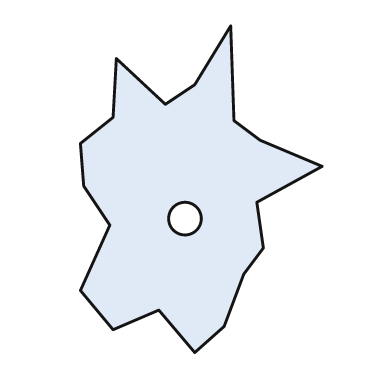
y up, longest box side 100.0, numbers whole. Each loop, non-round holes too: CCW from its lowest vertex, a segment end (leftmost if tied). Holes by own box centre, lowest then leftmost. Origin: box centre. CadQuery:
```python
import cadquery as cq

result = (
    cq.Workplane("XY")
    .moveTo(-2.0, -50.0)
    .lineTo(7.0, -42.0)
    .lineTo(13.0, -26.0)
    .lineTo(19.0, -18.0)
    .lineTo(17.0, -4.0)
    .lineTo(37.0, 7.0)
    .lineTo(18.0, 15.0)
    .lineTo(10.0, 21.0)
    .lineTo(9.0, 50.0)
    .lineTo(-2.0, 32.0)
    .lineTo(-11.0, 26.0)
    .lineTo(-26.0, 40.0)
    .lineTo(-27.0, 22.0)
    .lineTo(-37.0, 14.0)
    .lineTo(-36.0, 1.0)
    .lineTo(-28.0, -11.0)
    .lineTo(-37.0, -31.0)
    .lineTo(-27.0, -43.0)
    .lineTo(-13.0, -37.0)
    .close()
    .moveTo(-5.0, -9.0)
    .circle(5.0)
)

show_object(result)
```